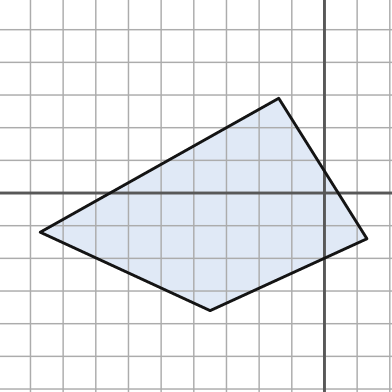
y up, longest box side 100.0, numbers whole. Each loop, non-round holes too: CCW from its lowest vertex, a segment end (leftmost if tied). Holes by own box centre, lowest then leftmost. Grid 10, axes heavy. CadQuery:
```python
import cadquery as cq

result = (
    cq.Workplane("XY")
    .moveTo(-35.0, -36.0)
    .lineTo(13.0, -14.0)
    .lineTo(-14.0, 29.0)
    .lineTo(-87.0, -12.0)
    .close()
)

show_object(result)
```